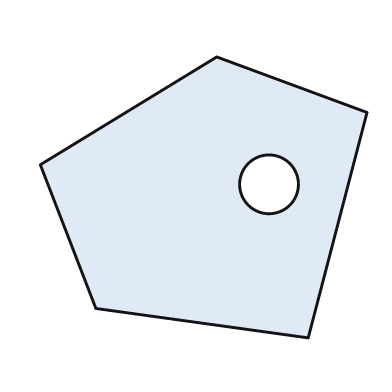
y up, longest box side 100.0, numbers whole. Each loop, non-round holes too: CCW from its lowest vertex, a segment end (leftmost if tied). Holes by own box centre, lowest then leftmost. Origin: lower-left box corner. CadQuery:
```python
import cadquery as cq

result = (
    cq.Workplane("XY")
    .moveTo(82.0, 0.0)
    .lineTo(100.0, 69.0)
    .lineTo(54.0, 86.0)
    .lineTo(0.0, 53.0)
    .lineTo(17.0, 9.0)
    .close()
    .moveTo(70.0, 47.0)
    .circle(9.0)
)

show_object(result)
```